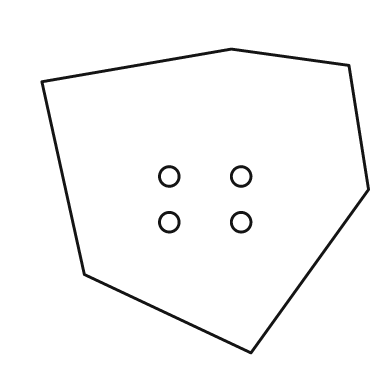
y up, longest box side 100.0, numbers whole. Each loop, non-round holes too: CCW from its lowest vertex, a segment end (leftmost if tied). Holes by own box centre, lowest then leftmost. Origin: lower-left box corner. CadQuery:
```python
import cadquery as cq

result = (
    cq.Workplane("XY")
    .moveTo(64.0, 0.0)
    .lineTo(100.0, 50.0)
    .lineTo(94.0, 88.0)
    .lineTo(58.0, 93.0)
    .lineTo(0.0, 83.0)
    .lineTo(13.0, 24.0)
    .close()
    .moveTo(39.0, 40.0)
    .circle(3.0)
    .moveTo(61.0, 40.0)
    .circle(3.0)
    .moveTo(39.0, 54.0)
    .circle(3.0)
    .moveTo(61.0, 54.0)
    .circle(3.0)
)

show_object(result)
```